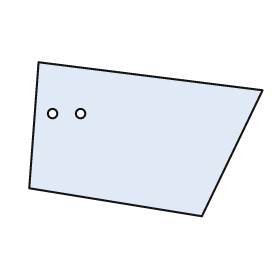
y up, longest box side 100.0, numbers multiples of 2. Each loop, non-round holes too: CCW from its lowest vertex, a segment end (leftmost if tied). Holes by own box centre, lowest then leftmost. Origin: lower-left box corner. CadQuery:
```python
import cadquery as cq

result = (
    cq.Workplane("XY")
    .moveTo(74.0, 0.0)
    .lineTo(100.0, 54.0)
    .lineTo(4.0, 66.0)
    .lineTo(0.0, 12.0)
    .close()
    .moveTo(10.0, 44.0)
    .circle(2.0)
    .moveTo(22.0, 44.0)
    .circle(2.0)
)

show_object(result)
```